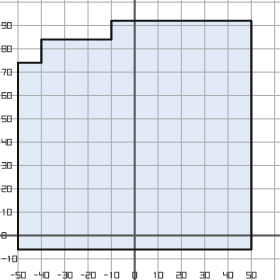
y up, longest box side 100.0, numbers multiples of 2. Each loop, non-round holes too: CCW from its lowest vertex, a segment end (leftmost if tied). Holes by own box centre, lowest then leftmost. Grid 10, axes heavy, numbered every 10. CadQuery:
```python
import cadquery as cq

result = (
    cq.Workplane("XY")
    .moveTo(-50.0, -6.0)
    .lineTo(50.0, -6.0)
    .lineTo(50.0, 92.0)
    .lineTo(-10.0, 92.0)
    .lineTo(-10.0, 84.0)
    .lineTo(-40.0, 84.0)
    .lineTo(-40.0, 74.0)
    .lineTo(-50.0, 74.0)
    .close()
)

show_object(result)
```